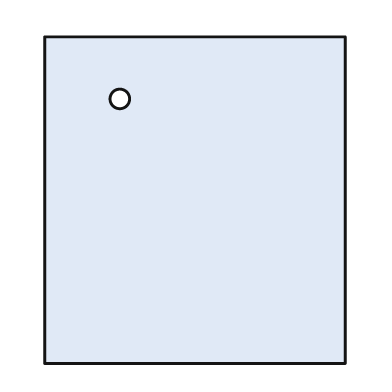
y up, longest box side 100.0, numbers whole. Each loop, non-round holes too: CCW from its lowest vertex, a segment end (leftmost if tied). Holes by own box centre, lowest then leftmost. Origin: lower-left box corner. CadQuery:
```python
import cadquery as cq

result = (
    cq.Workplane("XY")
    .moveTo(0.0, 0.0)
    .lineTo(92.0, 0.0)
    .lineTo(92.0, 100.0)
    .lineTo(0.0, 100.0)
    .close()
    .moveTo(23.0, 81.0)
    .circle(3.0)
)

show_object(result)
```